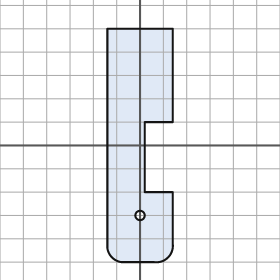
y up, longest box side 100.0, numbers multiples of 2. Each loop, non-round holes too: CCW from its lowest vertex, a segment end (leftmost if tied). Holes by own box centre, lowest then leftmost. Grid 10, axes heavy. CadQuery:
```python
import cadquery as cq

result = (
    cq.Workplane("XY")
    .moveTo(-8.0, -50.0)
    .lineTo(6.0, -50.0)
    .threePointArc((12.0, -48.0), (14.0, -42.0))
    .lineTo(14.0, -20.0)
    .lineTo(2.0, -20.0)
    .lineTo(2.0, 10.0)
    .lineTo(14.0, 10.0)
    .lineTo(14.0, 50.0)
    .lineTo(-14.0, 50.0)
    .lineTo(-14.0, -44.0)
    .threePointArc((-12.0, -48.0), (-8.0, -50.0))
    .close()
    .moveTo(0.0, -30.0)
    .circle(2.0)
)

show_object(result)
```